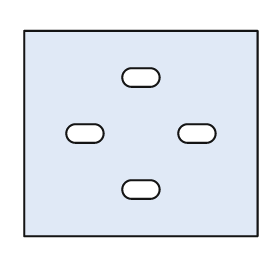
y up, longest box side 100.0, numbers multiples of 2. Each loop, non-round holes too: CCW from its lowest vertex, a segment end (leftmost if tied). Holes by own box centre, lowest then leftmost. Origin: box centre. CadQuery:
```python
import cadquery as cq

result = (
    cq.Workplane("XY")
    .moveTo(-50.0, -44.0)
    .lineTo(50.0, -44.0)
    .lineTo(50.0, 44.0)
    .lineTo(-50.0, 44.0)
    .close()
    .moveTo(-4.0, -28.0)
    .lineTo(4.0, -28.0)
    .threePointArc((8.0, -24.0), (4.0, -20.0))
    .lineTo(-4.0, -20.0)
    .threePointArc((-8.0, -24.0), (-4.0, -28.0))
    .close()
    .moveTo(-28.0, -4.0)
    .lineTo(-20.0, -4.0)
    .threePointArc((-16.0, 0.0), (-20.0, 4.0))
    .lineTo(-28.0, 4.0)
    .threePointArc((-32.0, 0.0), (-28.0, -4.0))
    .close()
    .moveTo(20.0, -4.0)
    .lineTo(28.0, -4.0)
    .threePointArc((32.0, 0.0), (28.0, 4.0))
    .lineTo(20.0, 4.0)
    .threePointArc((16.0, 0.0), (20.0, -4.0))
    .close()
    .moveTo(-4.0, 20.0)
    .lineTo(4.0, 20.0)
    .threePointArc((8.0, 24.0), (4.0, 28.0))
    .lineTo(-4.0, 28.0)
    .threePointArc((-8.0, 24.0), (-4.0, 20.0))
    .close()
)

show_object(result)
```